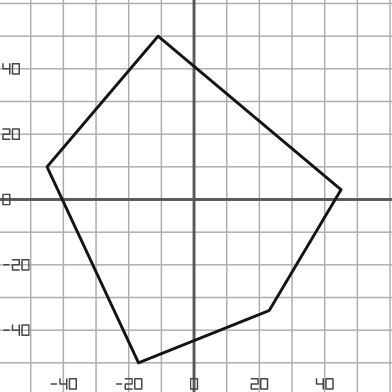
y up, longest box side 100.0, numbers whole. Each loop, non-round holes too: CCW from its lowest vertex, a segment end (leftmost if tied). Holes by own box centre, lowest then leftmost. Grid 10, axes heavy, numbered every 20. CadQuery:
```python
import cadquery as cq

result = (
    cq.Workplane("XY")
    .moveTo(-17.0, -50.0)
    .lineTo(23.0, -34.0)
    .lineTo(45.0, 3.0)
    .lineTo(-11.0, 50.0)
    .lineTo(-45.0, 10.0)
    .close()
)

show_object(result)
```